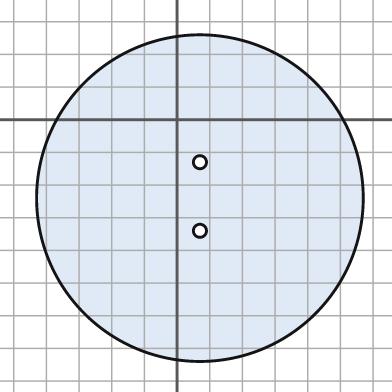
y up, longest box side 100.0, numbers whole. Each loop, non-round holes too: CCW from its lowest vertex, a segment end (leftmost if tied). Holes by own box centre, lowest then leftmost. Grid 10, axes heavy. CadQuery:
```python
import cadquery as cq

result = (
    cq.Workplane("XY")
    .moveTo(7.0, -24.0)
    .circle(50.0)
    .moveTo(7.0, -34.0)
    .circle(2.0)
    .moveTo(7.0, -13.0)
    .circle(2.0)
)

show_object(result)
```